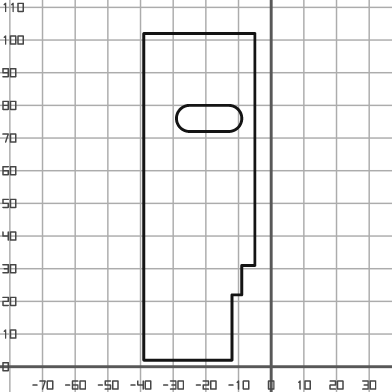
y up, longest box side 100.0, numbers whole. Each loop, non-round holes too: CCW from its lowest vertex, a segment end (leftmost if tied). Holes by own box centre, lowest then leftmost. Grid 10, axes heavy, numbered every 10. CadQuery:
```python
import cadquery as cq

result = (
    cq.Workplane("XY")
    .moveTo(-39.0, 2.0)
    .lineTo(-12.0, 2.0)
    .lineTo(-12.0, 22.0)
    .lineTo(-9.0, 22.0)
    .lineTo(-9.0, 31.0)
    .lineTo(-5.0, 31.0)
    .lineTo(-5.0, 102.0)
    .lineTo(-39.0, 102.0)
    .close()
    .moveTo(-25.0, 72.0)
    .lineTo(-13.0, 72.0)
    .threePointArc((-9.0, 76.0), (-13.0, 80.0))
    .lineTo(-25.0, 80.0)
    .threePointArc((-29.0, 76.0), (-25.0, 72.0))
    .close()
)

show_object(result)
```